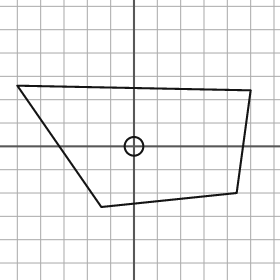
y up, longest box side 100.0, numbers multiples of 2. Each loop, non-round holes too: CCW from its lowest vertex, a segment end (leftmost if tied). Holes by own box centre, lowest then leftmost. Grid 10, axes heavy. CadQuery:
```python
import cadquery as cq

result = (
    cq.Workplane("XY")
    .moveTo(-14.0, -26.0)
    .lineTo(44.0, -20.0)
    .lineTo(50.0, 24.0)
    .lineTo(-50.0, 26.0)
    .close()
    .moveTo(0.0, 0.0)
    .circle(4.0)
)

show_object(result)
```